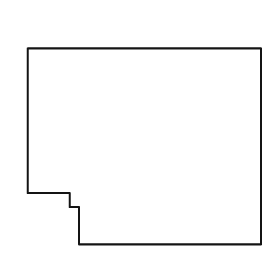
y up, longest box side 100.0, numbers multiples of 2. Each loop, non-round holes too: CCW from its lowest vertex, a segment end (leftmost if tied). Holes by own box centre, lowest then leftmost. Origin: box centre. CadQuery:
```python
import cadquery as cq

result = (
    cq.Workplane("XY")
    .moveTo(-28.0, -42.0)
    .lineTo(50.0, -42.0)
    .lineTo(50.0, 42.0)
    .lineTo(-50.0, 42.0)
    .lineTo(-50.0, -20.0)
    .lineTo(-32.0, -20.0)
    .lineTo(-32.0, -26.0)
    .lineTo(-28.0, -26.0)
    .close()
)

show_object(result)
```